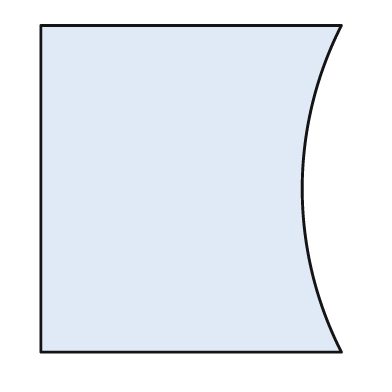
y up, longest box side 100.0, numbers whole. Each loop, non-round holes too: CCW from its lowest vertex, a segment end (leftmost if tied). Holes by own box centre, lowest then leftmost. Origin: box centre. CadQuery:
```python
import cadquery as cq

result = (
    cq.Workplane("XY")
    .moveTo(-46.0, -50.0)
    .lineTo(46.0, -50.0)
    .threePointArc((34.0, 0.0), (46.0, 50.0))
    .lineTo(-46.0, 50.0)
    .close()
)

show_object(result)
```